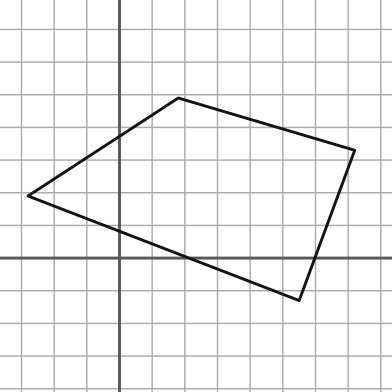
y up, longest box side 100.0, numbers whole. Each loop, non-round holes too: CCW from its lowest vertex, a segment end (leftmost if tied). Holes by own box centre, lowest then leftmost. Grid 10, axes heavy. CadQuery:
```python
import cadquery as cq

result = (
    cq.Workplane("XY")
    .moveTo(55.0, -13.0)
    .lineTo(72.0, 33.0)
    .lineTo(18.0, 49.0)
    .lineTo(-28.0, 19.0)
    .close()
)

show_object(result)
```